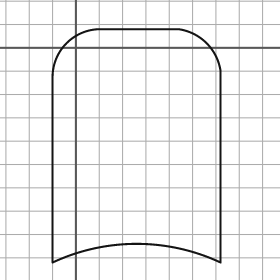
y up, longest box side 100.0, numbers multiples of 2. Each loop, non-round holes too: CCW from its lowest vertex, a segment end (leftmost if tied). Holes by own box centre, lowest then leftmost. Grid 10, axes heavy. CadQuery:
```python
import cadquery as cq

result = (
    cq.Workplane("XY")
    .moveTo(-10.0, -92.0)
    .threePointArc((26.0, -84.0), (62.0, -92.0))
    .lineTo(62.0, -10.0)
    .threePointArc((56.0, 2.0), (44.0, 8.0))
    .lineTo(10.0, 8.0)
    .threePointArc((-4.0, 2.0), (-10.0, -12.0))
    .close()
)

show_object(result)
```